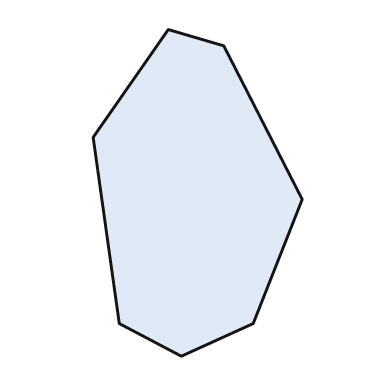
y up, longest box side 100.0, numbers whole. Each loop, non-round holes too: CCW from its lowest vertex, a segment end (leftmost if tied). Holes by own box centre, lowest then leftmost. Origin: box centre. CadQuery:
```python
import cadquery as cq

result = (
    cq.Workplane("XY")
    .moveTo(-5.0, -50.0)
    .lineTo(17.0, -40.0)
    .lineTo(32.0, -2.0)
    .lineTo(8.0, 45.0)
    .lineTo(-9.0, 50.0)
    .lineTo(-32.0, 17.0)
    .lineTo(-24.0, -40.0)
    .close()
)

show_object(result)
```